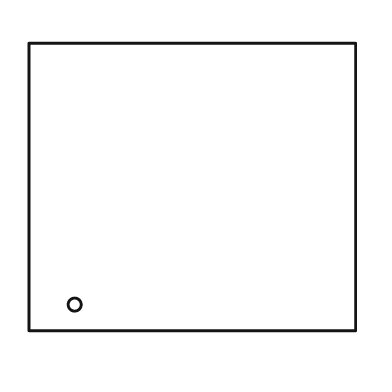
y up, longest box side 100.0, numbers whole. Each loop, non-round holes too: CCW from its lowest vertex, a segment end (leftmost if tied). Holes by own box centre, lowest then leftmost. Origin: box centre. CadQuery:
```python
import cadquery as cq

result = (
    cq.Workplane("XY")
    .moveTo(-50.0, -44.0)
    .lineTo(50.0, -44.0)
    .lineTo(50.0, 44.0)
    .lineTo(-50.0, 44.0)
    .close()
    .moveTo(-36.0, -36.0)
    .circle(2.0)
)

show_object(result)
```